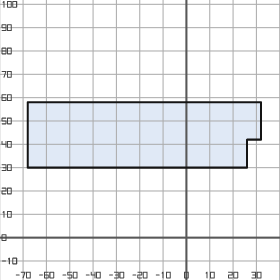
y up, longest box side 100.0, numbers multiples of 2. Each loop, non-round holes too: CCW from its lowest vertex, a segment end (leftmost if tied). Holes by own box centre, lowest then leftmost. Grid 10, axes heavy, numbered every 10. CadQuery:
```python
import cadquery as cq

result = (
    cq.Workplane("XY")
    .moveTo(-68.0, 30.0)
    .lineTo(26.0, 30.0)
    .lineTo(26.0, 42.0)
    .lineTo(32.0, 42.0)
    .lineTo(32.0, 58.0)
    .lineTo(-68.0, 58.0)
    .close()
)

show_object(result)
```